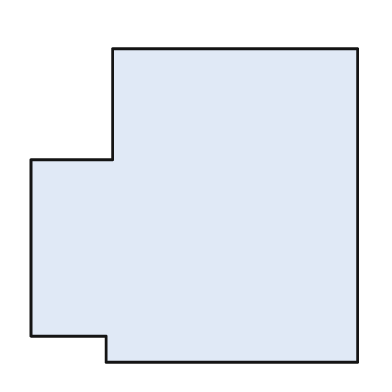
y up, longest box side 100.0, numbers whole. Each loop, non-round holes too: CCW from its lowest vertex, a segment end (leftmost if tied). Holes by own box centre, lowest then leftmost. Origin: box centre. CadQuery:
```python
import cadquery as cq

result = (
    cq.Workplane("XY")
    .moveTo(-27.0, -48.0)
    .lineTo(50.0, -48.0)
    .lineTo(50.0, 48.0)
    .lineTo(-25.0, 48.0)
    .lineTo(-25.0, 14.0)
    .lineTo(-50.0, 14.0)
    .lineTo(-50.0, -40.0)
    .lineTo(-27.0, -40.0)
    .close()
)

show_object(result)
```